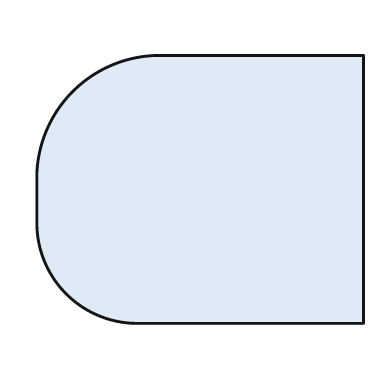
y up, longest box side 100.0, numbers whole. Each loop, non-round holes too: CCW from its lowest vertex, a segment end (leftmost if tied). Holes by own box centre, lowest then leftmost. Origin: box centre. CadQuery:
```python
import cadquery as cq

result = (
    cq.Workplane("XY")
    .moveTo(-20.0, -41.0)
    .lineTo(50.0, -41.0)
    .lineTo(50.0, 41.0)
    .lineTo(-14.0, 41.0)
    .threePointArc((-39.0, 30.0), (-50.0, 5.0))
    .lineTo(-50.0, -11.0)
    .threePointArc((-41.0, -32.0), (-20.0, -41.0))
    .close()
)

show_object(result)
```